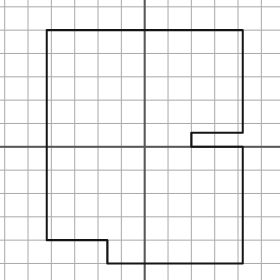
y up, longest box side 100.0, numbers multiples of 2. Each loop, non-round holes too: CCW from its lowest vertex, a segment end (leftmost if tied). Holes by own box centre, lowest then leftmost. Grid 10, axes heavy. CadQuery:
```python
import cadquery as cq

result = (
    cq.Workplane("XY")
    .moveTo(-16.0, -50.0)
    .lineTo(42.0, -50.0)
    .lineTo(42.0, 0.0)
    .lineTo(20.0, 0.0)
    .lineTo(20.0, 6.0)
    .lineTo(42.0, 6.0)
    .lineTo(42.0, 50.0)
    .lineTo(-42.0, 50.0)
    .lineTo(-42.0, -40.0)
    .lineTo(-16.0, -40.0)
    .close()
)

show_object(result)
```